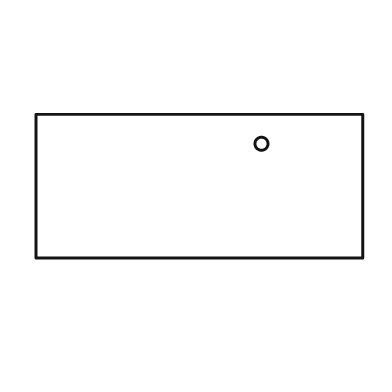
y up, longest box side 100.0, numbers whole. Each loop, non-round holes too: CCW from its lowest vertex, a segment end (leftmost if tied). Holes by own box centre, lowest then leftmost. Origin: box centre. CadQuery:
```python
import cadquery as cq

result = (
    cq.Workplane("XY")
    .moveTo(-50.0, -22.0)
    .lineTo(50.0, -22.0)
    .lineTo(50.0, 22.0)
    .lineTo(-50.0, 22.0)
    .close()
    .moveTo(19.0, 13.0)
    .circle(2.0)
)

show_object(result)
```